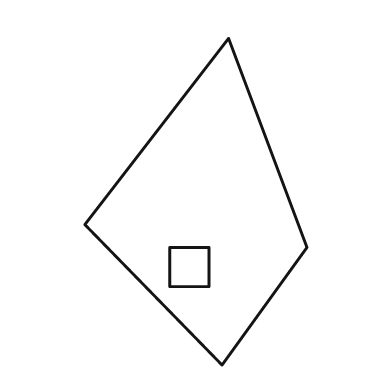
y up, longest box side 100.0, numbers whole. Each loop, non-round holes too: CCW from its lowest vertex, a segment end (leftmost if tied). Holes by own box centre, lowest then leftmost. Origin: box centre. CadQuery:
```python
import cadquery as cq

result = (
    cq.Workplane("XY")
    .moveTo(8.0, -50.0)
    .lineTo(34.0, -14.0)
    .lineTo(10.0, 50.0)
    .lineTo(-34.0, -7.0)
    .close()
    .moveTo(-8.0, -26.0)
    .lineTo(4.0, -26.0)
    .lineTo(4.0, -14.0)
    .lineTo(-8.0, -14.0)
    .close()
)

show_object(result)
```